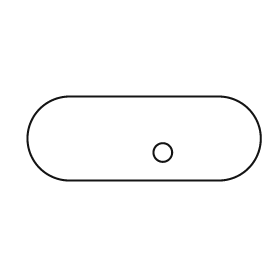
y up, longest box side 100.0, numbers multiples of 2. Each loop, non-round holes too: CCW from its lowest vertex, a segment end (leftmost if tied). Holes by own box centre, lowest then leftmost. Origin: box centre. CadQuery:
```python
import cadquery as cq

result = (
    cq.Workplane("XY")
    .moveTo(-32.0, -18.0)
    .lineTo(32.0, -18.0)
    .threePointArc((50.0, 0.0), (32.0, 18.0))
    .lineTo(-32.0, 18.0)
    .threePointArc((-50.0, 0.0), (-32.0, -18.0))
    .close()
    .moveTo(8.0, -6.0)
    .circle(4.0)
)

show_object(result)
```